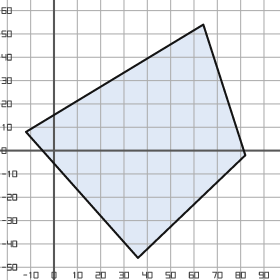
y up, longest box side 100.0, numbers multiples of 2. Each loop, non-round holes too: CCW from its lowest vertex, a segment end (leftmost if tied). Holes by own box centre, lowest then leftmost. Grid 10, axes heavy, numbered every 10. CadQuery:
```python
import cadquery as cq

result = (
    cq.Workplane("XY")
    .moveTo(36.0, -46.0)
    .lineTo(82.0, -2.0)
    .lineTo(64.0, 54.0)
    .lineTo(-12.0, 8.0)
    .close()
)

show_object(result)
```